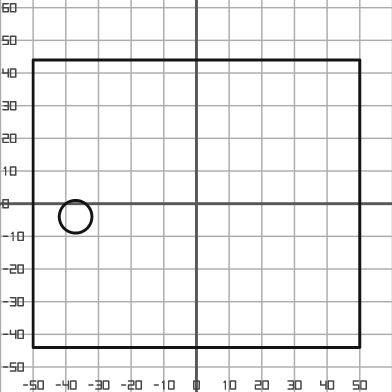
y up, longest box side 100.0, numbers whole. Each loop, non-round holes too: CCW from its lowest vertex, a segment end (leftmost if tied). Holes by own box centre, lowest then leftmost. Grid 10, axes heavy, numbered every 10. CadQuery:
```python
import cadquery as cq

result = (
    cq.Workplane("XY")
    .moveTo(-50.0, -44.0)
    .lineTo(50.0, -44.0)
    .lineTo(50.0, 44.0)
    .lineTo(-50.0, 44.0)
    .close()
    .moveTo(-37.0, -4.0)
    .circle(5.0)
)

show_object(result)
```